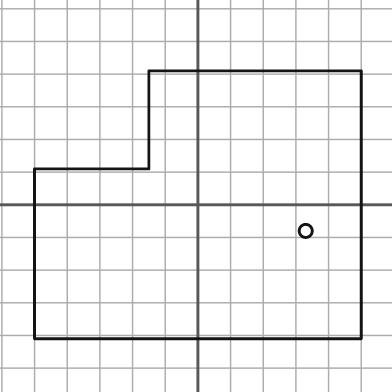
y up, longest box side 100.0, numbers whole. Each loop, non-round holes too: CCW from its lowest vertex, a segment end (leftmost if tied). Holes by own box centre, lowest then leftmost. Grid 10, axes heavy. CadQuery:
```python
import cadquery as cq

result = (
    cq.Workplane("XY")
    .moveTo(-50.0, -41.0)
    .lineTo(50.0, -41.0)
    .lineTo(50.0, 41.0)
    .lineTo(-15.0, 41.0)
    .lineTo(-15.0, 11.0)
    .lineTo(-50.0, 11.0)
    .close()
    .moveTo(33.0, -8.0)
    .circle(2.0)
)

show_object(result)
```